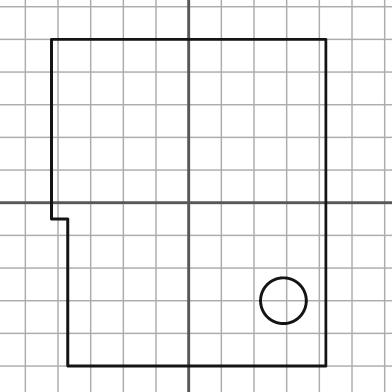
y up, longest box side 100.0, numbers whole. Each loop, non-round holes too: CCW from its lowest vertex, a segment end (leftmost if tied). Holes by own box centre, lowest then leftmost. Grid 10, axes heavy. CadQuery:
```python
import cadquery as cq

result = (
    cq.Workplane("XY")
    .moveTo(-37.0, -50.0)
    .lineTo(42.0, -50.0)
    .lineTo(42.0, 50.0)
    .lineTo(-42.0, 50.0)
    .lineTo(-42.0, -5.0)
    .lineTo(-37.0, -5.0)
    .close()
    .moveTo(29.0, -30.0)
    .circle(7.0)
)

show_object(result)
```